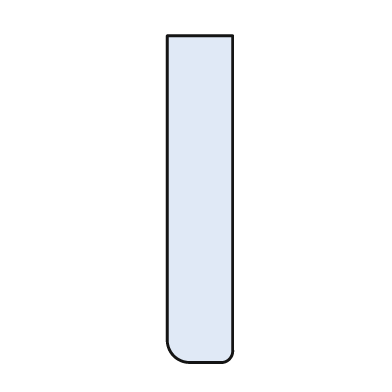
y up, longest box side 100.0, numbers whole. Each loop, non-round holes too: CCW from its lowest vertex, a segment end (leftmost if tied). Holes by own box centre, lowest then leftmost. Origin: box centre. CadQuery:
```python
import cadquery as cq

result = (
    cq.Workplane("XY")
    .moveTo(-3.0, -50.0)
    .lineTo(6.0, -50.0)
    .threePointArc((9.0, -49.0), (10.0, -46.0))
    .lineTo(10.0, 50.0)
    .lineTo(-10.0, 50.0)
    .lineTo(-10.0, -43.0)
    .threePointArc((-8.0, -48.0), (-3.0, -50.0))
    .close()
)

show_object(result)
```